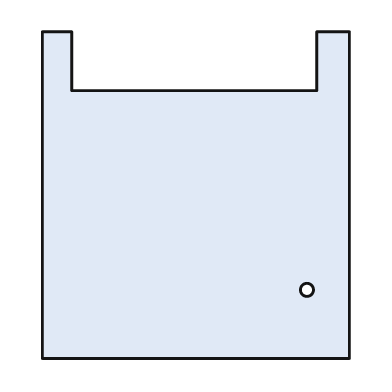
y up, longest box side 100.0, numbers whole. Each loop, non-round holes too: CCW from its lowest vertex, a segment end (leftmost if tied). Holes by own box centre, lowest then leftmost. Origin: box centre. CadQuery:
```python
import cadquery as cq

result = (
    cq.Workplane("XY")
    .moveTo(-47.0, -50.0)
    .lineTo(47.0, -50.0)
    .lineTo(47.0, 50.0)
    .lineTo(37.0, 50.0)
    .lineTo(37.0, 32.0)
    .lineTo(-38.0, 32.0)
    .lineTo(-38.0, 50.0)
    .lineTo(-47.0, 50.0)
    .close()
    .moveTo(34.0, -29.0)
    .circle(2.0)
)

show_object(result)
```